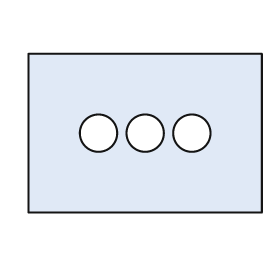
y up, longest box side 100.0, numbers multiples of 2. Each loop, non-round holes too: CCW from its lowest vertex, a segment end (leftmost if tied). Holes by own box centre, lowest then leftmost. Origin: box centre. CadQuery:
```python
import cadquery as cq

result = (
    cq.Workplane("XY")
    .moveTo(-50.0, -34.0)
    .lineTo(50.0, -34.0)
    .lineTo(50.0, 34.0)
    .lineTo(-50.0, 34.0)
    .close()
    .moveTo(-20.0, 0.0)
    .circle(8.0)
    .moveTo(0.0, 0.0)
    .circle(8.0)
    .moveTo(20.0, 0.0)
    .circle(8.0)
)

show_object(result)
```